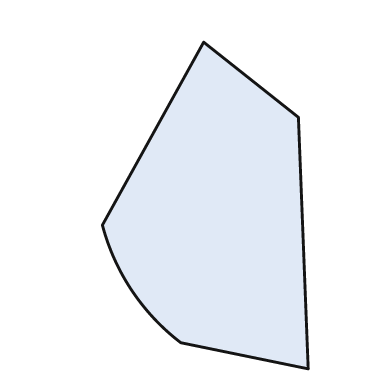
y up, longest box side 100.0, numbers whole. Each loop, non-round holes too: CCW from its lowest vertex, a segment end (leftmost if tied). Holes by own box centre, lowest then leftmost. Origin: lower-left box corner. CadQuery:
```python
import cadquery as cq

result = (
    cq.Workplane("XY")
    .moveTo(63.0, 0.0)
    .lineTo(60.0, 77.0)
    .lineTo(31.0, 100.0)
    .lineTo(0.0, 44.0)
    .threePointArc((9.0, 24.0), (24.0, 8.0))
    .close()
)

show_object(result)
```